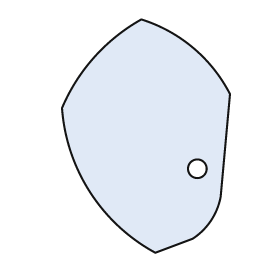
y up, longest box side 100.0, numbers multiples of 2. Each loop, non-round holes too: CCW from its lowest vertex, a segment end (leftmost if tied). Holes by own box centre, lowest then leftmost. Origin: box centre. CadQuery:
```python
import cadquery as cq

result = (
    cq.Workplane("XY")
    .moveTo(4.0, -50.0)
    .lineTo(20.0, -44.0)
    .threePointArc((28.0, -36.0), (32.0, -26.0))
    .lineTo(36.0, 18.0)
    .threePointArc((20.0, 38.0), (-2.0, 50.0))
    .threePointArc((-22.0, 34.0), (-36.0, 12.0))
    .threePointArc((-24.0, -24.0), (4.0, -50.0))
    .close()
    .moveTo(22.0, -14.0)
    .circle(4.0)
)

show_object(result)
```